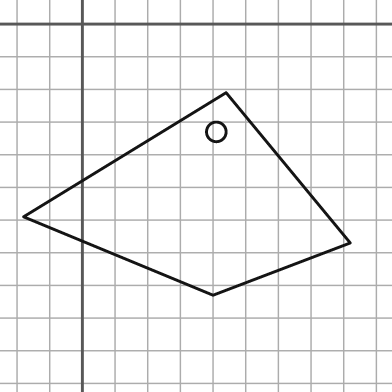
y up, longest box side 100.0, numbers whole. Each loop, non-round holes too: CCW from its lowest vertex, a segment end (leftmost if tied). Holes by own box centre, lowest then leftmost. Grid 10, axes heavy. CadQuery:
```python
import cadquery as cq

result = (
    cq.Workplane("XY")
    .moveTo(40.0, -83.0)
    .lineTo(82.0, -67.0)
    .lineTo(44.0, -21.0)
    .lineTo(-18.0, -59.0)
    .close()
    .moveTo(41.0, -33.0)
    .circle(3.0)
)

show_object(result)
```